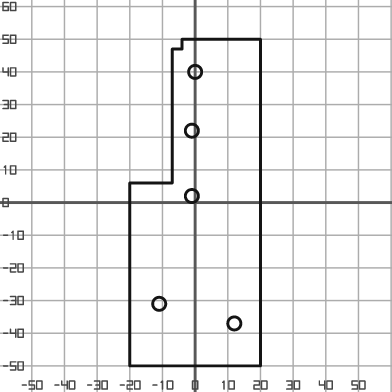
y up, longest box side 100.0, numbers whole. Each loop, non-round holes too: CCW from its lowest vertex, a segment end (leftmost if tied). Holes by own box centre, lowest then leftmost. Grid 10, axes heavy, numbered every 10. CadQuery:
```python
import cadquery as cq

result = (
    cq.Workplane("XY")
    .moveTo(-20.0, -50.0)
    .lineTo(20.0, -50.0)
    .lineTo(20.0, 50.0)
    .lineTo(-4.0, 50.0)
    .lineTo(-4.0, 47.0)
    .lineTo(-7.0, 47.0)
    .lineTo(-7.0, 6.0)
    .lineTo(-20.0, 6.0)
    .close()
    .moveTo(12.0, -37.0)
    .circle(2.0)
    .moveTo(-11.0, -31.0)
    .circle(2.0)
    .moveTo(-1.0, 2.0)
    .circle(2.0)
    .moveTo(-1.0, 22.0)
    .circle(2.0)
    .moveTo(0.0, 40.0)
    .circle(2.0)
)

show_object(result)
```